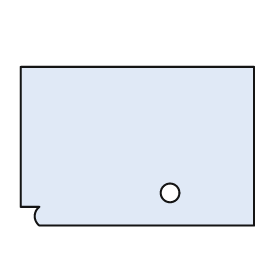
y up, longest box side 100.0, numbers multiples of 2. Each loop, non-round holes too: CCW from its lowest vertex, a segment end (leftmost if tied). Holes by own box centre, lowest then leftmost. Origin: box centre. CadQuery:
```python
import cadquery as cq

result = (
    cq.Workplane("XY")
    .moveTo(-42.0, -34.0)
    .lineTo(50.0, -34.0)
    .lineTo(50.0, 34.0)
    .lineTo(-50.0, 34.0)
    .lineTo(-50.0, -26.0)
    .lineTo(-42.0, -26.0)
    .threePointArc((-44.0, -30.0), (-42.0, -34.0))
    .close()
    .moveTo(14.0, -20.0)
    .circle(4.0)
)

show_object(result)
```